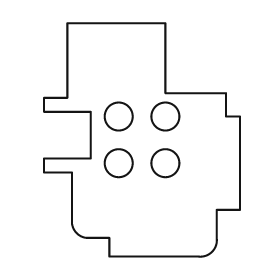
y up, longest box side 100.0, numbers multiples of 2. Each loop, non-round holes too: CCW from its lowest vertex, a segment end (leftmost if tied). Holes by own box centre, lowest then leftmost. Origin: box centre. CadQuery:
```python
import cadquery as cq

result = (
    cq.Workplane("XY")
    .moveTo(-14.0, -50.0)
    .lineTo(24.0, -50.0)
    .threePointArc((30.0, -48.0), (32.0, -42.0))
    .lineTo(32.0, -30.0)
    .lineTo(42.0, -30.0)
    .lineTo(42.0, 10.0)
    .lineTo(36.0, 10.0)
    .lineTo(36.0, 20.0)
    .lineTo(10.0, 20.0)
    .lineTo(10.0, 50.0)
    .lineTo(-32.0, 50.0)
    .lineTo(-32.0, 18.0)
    .lineTo(-42.0, 18.0)
    .lineTo(-42.0, 12.0)
    .lineTo(-22.0, 12.0)
    .lineTo(-22.0, -8.0)
    .lineTo(-42.0, -8.0)
    .lineTo(-42.0, -14.0)
    .lineTo(-30.0, -14.0)
    .lineTo(-30.0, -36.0)
    .threePointArc((-28.0, -40.0), (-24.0, -42.0))
    .lineTo(-14.0, -42.0)
    .close()
    .moveTo(-10.0, -10.0)
    .circle(6.0)
    .moveTo(10.0, -10.0)
    .circle(6.0)
    .moveTo(-10.0, 10.0)
    .circle(6.0)
    .moveTo(10.0, 10.0)
    .circle(6.0)
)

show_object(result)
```